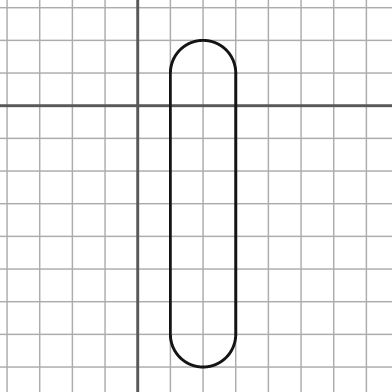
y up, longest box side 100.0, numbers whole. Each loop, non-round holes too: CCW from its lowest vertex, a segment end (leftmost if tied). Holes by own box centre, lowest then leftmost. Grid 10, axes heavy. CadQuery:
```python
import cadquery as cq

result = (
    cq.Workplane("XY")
    .moveTo(10.0, -70.0)
    .threePointArc((20.0, -80.0), (30.0, -70.0))
    .lineTo(30.0, 10.0)
    .threePointArc((20.0, 20.0), (10.0, 10.0))
    .close()
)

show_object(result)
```